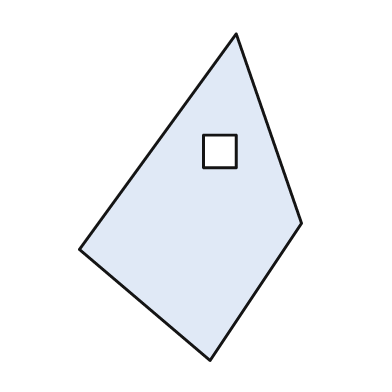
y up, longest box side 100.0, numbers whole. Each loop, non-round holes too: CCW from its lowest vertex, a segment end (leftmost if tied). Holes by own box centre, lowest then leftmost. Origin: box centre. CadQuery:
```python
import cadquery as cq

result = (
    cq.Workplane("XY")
    .moveTo(6.0, -50.0)
    .lineTo(34.0, -8.0)
    .lineTo(14.0, 50.0)
    .lineTo(-34.0, -16.0)
    .close()
    .moveTo(4.0, 9.0)
    .lineTo(14.0, 9.0)
    .lineTo(14.0, 19.0)
    .lineTo(4.0, 19.0)
    .close()
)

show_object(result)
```